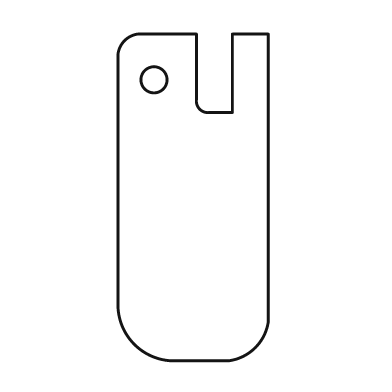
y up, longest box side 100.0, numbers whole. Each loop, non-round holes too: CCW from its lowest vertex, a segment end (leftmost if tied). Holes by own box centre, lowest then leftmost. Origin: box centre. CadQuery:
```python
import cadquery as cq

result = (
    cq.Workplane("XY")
    .moveTo(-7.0, -50.0)
    .lineTo(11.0, -50.0)
    .threePointArc((19.0, -46.0), (23.0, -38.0))
    .lineTo(23.0, 50.0)
    .lineTo(12.0, 50.0)
    .lineTo(12.0, 26.0)
    .lineTo(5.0, 26.0)
    .threePointArc((2.0, 27.0), (1.0, 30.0))
    .lineTo(1.0, 50.0)
    .lineTo(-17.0, 50.0)
    .threePointArc((-21.0, 48.0), (-23.0, 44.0))
    .lineTo(-23.0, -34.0)
    .threePointArc((-18.0, -45.0), (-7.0, -50.0))
    .close()
    .moveTo(-12.0, 36.0)
    .circle(4.0)
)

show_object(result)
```